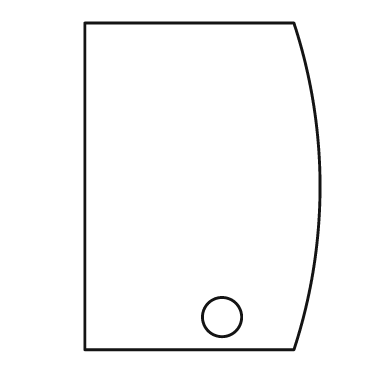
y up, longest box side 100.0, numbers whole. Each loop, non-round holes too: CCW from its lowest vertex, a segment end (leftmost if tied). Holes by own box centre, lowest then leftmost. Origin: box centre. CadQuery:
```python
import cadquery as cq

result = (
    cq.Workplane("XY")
    .moveTo(-36.0, -50.0)
    .lineTo(28.0, -50.0)
    .threePointArc((36.0, 0.0), (28.0, 50.0))
    .lineTo(-36.0, 50.0)
    .close()
    .moveTo(6.0, -40.0)
    .circle(6.0)
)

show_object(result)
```